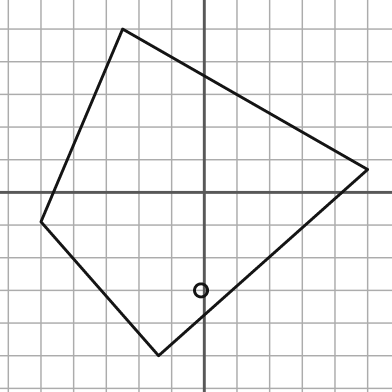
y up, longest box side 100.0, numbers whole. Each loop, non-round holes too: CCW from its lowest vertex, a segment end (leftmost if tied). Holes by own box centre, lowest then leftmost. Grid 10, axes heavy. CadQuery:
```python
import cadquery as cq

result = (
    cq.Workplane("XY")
    .moveTo(-14.0, -50.0)
    .lineTo(50.0, 7.0)
    .lineTo(-25.0, 50.0)
    .lineTo(-50.0, -9.0)
    .close()
    .moveTo(-1.0, -30.0)
    .circle(2.0)
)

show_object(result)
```